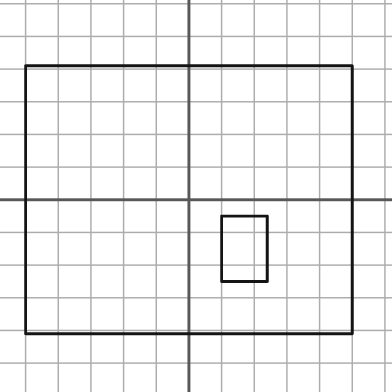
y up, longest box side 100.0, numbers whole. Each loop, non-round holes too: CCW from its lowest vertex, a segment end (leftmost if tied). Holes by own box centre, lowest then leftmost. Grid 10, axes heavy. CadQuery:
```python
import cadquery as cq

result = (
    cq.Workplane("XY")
    .moveTo(-50.0, -41.0)
    .lineTo(50.0, -41.0)
    .lineTo(50.0, 41.0)
    .lineTo(-50.0, 41.0)
    .close()
    .moveTo(10.0, -25.0)
    .lineTo(24.0, -25.0)
    .lineTo(24.0, -5.0)
    .lineTo(10.0, -5.0)
    .close()
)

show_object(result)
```